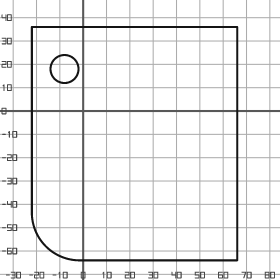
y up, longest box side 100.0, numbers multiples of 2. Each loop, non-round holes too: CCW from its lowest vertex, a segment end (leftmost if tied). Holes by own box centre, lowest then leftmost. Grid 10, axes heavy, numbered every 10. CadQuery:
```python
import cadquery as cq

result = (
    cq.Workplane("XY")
    .moveTo(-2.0, -64.0)
    .lineTo(66.0, -64.0)
    .lineTo(66.0, 36.0)
    .lineTo(-22.0, 36.0)
    .lineTo(-22.0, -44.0)
    .threePointArc((-16.0, -58.0), (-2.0, -64.0))
    .close()
    .moveTo(-8.0, 18.0)
    .circle(6.0)
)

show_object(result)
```